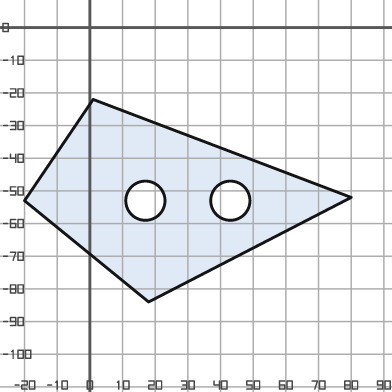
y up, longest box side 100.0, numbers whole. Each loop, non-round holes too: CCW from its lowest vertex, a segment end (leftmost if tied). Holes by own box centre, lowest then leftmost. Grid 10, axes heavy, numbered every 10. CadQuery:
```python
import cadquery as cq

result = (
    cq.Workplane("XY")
    .moveTo(18.0, -84.0)
    .lineTo(80.0, -52.0)
    .lineTo(1.0, -22.0)
    .lineTo(-20.0, -53.0)
    .close()
    .moveTo(17.0, -53.0)
    .circle(6.0)
    .moveTo(43.0, -53.0)
    .circle(6.0)
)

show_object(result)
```